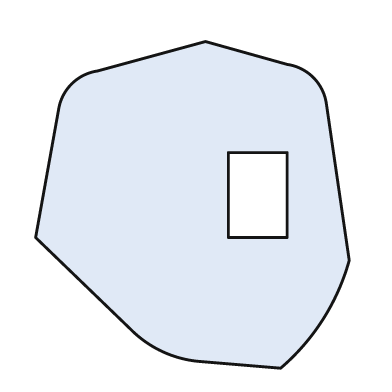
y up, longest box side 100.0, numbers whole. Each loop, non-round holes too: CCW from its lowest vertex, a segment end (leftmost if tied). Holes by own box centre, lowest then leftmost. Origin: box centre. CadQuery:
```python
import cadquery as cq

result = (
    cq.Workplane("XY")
    .moveTo(27.0, -50.0)
    .threePointArc((40.0, -35.0), (48.0, -17.0))
    .lineTo(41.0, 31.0)
    .threePointArc((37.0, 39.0), (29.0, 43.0))
    .lineTo(4.0, 50.0)
    .lineTo(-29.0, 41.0)
    .threePointArc((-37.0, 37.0), (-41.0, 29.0))
    .lineTo(-48.0, -10.0)
    .lineTo(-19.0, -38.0)
    .threePointArc((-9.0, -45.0), (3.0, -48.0))
    .close()
    .moveTo(11.0, -10.0)
    .lineTo(29.0, -10.0)
    .lineTo(29.0, 16.0)
    .lineTo(11.0, 16.0)
    .close()
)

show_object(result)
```